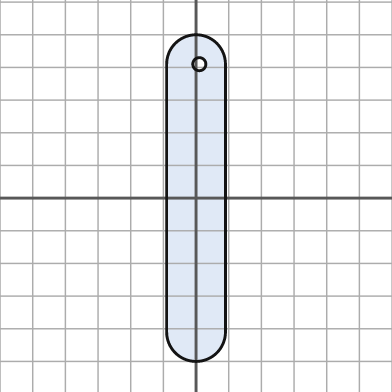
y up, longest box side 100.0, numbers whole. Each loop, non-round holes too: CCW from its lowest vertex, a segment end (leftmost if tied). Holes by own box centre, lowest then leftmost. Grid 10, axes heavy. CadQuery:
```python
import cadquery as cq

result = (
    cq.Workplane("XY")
    .moveTo(-9.0, -41.0)
    .threePointArc((0.0, -50.0), (9.0, -41.0))
    .lineTo(9.0, 41.0)
    .threePointArc((0.0, 50.0), (-9.0, 41.0))
    .close()
    .moveTo(1.0, 41.0)
    .circle(2.0)
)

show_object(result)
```